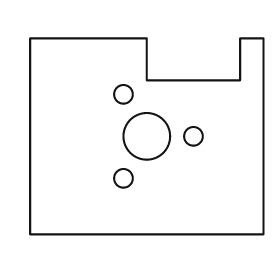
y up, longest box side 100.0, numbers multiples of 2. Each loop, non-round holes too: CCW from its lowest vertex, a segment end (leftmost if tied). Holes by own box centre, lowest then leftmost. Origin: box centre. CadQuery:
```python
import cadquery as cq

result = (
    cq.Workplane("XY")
    .moveTo(-50.0, -42.0)
    .lineTo(50.0, -42.0)
    .lineTo(50.0, 42.0)
    .lineTo(40.0, 42.0)
    .lineTo(40.0, 24.0)
    .lineTo(0.0, 24.0)
    .lineTo(0.0, 42.0)
    .lineTo(-50.0, 42.0)
    .close()
    .moveTo(-10.0, -18.0)
    .circle(4.0)
    .moveTo(0.0, 0.0)
    .circle(10.0)
    .moveTo(20.0, 0.0)
    .circle(4.0)
    .moveTo(-10.0, 18.0)
    .circle(4.0)
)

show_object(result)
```